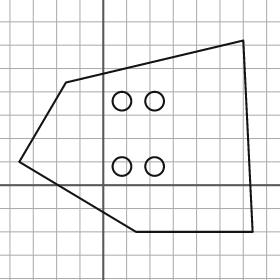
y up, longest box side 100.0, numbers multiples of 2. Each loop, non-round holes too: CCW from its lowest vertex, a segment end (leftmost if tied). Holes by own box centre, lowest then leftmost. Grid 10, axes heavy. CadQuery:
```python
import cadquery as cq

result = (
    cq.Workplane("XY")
    .moveTo(14.0, -20.0)
    .lineTo(64.0, -20.0)
    .lineTo(60.0, 62.0)
    .lineTo(-16.0, 44.0)
    .lineTo(-36.0, 10.0)
    .close()
    .moveTo(8.0, 8.0)
    .circle(4.0)
    .moveTo(22.0, 8.0)
    .circle(4.0)
    .moveTo(8.0, 36.0)
    .circle(4.0)
    .moveTo(22.0, 36.0)
    .circle(4.0)
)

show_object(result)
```